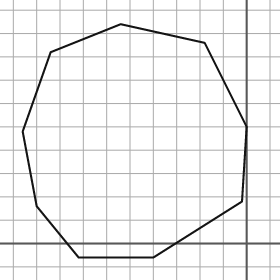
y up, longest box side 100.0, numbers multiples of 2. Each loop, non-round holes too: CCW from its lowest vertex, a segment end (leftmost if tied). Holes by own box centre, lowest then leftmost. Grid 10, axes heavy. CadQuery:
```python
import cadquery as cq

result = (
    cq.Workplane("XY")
    .moveTo(-72.0, -6.0)
    .lineTo(-40.0, -6.0)
    .lineTo(-2.0, 18.0)
    .lineTo(0.0, 50.0)
    .lineTo(-18.0, 86.0)
    .lineTo(-54.0, 94.0)
    .lineTo(-84.0, 82.0)
    .lineTo(-96.0, 48.0)
    .lineTo(-90.0, 16.0)
    .close()
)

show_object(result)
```